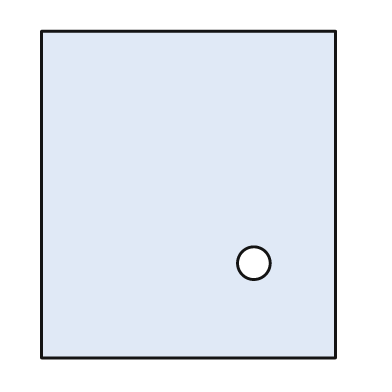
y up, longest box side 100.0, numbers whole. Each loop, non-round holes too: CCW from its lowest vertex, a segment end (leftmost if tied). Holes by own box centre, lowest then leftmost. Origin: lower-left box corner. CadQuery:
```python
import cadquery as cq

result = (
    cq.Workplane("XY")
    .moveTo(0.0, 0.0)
    .lineTo(90.0, 0.0)
    .lineTo(90.0, 100.0)
    .lineTo(0.0, 100.0)
    .close()
    .moveTo(65.0, 29.0)
    .circle(5.0)
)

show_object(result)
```